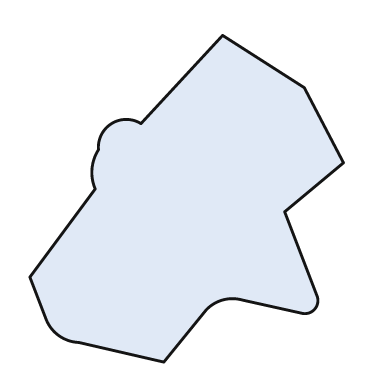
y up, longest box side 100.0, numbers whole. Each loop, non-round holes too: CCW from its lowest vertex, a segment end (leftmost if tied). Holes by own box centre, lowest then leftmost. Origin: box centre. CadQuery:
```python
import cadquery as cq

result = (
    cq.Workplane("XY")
    .moveTo(-7.0, -50.0)
    .lineTo(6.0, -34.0)
    .threePointArc((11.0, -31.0), (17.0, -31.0))
    .lineTo(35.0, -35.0)
    .threePointArc((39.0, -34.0), (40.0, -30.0))
    .lineTo(30.0, -4.0)
    .lineTo(48.0, 11.0)
    .lineTo(36.0, 34.0)
    .lineTo(11.0, 50.0)
    .lineTo(-14.0, 23.0)
    .threePointArc((-23.0, 23.0), (-27.0, 15.0))
    .threePointArc((-29.0, 9.0), (-28.0, 3.0))
    .lineTo(-48.0, -24.0)
    .lineTo(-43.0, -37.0)
    .threePointArc((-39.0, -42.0), (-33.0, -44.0))
    .close()
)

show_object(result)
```